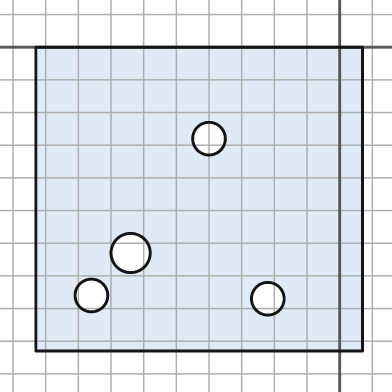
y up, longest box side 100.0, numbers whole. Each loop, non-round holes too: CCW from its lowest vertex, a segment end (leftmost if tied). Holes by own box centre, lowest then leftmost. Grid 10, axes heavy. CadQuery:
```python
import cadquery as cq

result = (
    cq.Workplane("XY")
    .moveTo(-93.0, -93.0)
    .lineTo(7.0, -93.0)
    .lineTo(7.0, 0.0)
    .lineTo(-93.0, 0.0)
    .close()
    .moveTo(-22.0, -77.0)
    .circle(5.0)
    .moveTo(-76.0, -76.0)
    .circle(5.0)
    .moveTo(-64.0, -63.0)
    .circle(6.0)
    .moveTo(-40.0, -28.0)
    .circle(5.0)
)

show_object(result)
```